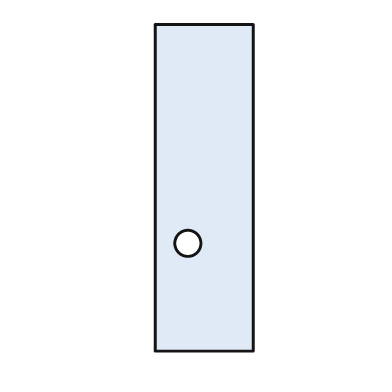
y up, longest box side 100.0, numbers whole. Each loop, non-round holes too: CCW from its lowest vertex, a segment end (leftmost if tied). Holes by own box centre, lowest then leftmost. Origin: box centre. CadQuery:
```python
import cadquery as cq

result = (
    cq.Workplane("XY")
    .moveTo(-15.0, -50.0)
    .lineTo(15.0, -50.0)
    .lineTo(15.0, 50.0)
    .lineTo(-15.0, 50.0)
    .close()
    .moveTo(-5.0, -17.0)
    .circle(4.0)
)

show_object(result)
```